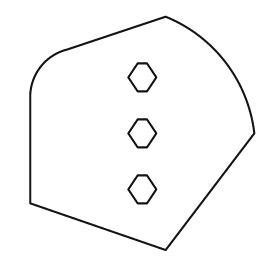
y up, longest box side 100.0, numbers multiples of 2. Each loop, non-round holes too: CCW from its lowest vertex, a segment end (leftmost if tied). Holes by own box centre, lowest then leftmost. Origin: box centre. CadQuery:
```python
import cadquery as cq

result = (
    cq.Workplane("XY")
    .moveTo(10.0, -50.0)
    .lineTo(48.0, 0.0)
    .threePointArc((36.0, 30.0), (10.0, 50.0))
    .lineTo(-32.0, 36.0)
    .threePointArc((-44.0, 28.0), (-48.0, 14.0))
    .lineTo(-48.0, -30.0)
    .close()
    .moveTo(-2.0, -30.0)
    .lineTo(2.0, -30.0)
    .lineTo(6.0, -24.0)
    .lineTo(2.0, -18.0)
    .lineTo(-2.0, -18.0)
    .lineTo(-6.0, -24.0)
    .close()
    .moveTo(-2.0, -6.0)
    .lineTo(2.0, -6.0)
    .lineTo(6.0, 0.0)
    .lineTo(2.0, 6.0)
    .lineTo(-2.0, 6.0)
    .lineTo(-6.0, 0.0)
    .close()
    .moveTo(-2.0, 18.0)
    .lineTo(2.0, 18.0)
    .lineTo(6.0, 24.0)
    .lineTo(2.0, 30.0)
    .lineTo(-2.0, 30.0)
    .lineTo(-6.0, 24.0)
    .close()
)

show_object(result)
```